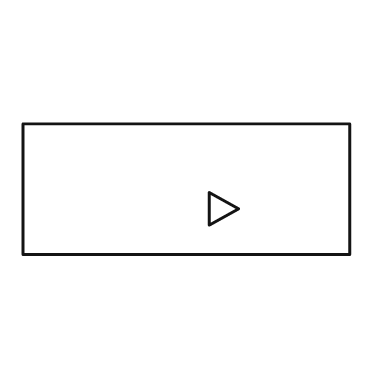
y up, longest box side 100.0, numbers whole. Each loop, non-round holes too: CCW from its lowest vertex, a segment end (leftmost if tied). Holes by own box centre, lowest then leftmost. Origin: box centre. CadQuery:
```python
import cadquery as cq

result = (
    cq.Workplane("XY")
    .moveTo(-50.0, -20.0)
    .lineTo(50.0, -20.0)
    .lineTo(50.0, 20.0)
    .lineTo(-50.0, 20.0)
    .close()
    .moveTo(7.0, -11.0)
    .lineTo(16.0, -6.0)
    .lineTo(7.0, -1.0)
    .close()
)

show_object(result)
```